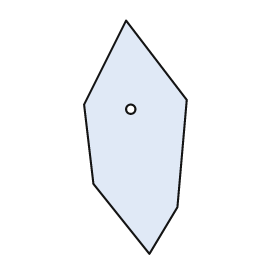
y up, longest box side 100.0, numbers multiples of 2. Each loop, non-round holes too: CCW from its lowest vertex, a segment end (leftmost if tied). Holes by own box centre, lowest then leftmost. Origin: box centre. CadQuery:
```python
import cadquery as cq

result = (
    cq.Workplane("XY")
    .moveTo(6.0, -50.0)
    .lineTo(18.0, -30.0)
    .lineTo(22.0, 16.0)
    .lineTo(-4.0, 50.0)
    .lineTo(-22.0, 14.0)
    .lineTo(-18.0, -20.0)
    .close()
    .moveTo(-2.0, 12.0)
    .circle(2.0)
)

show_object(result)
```